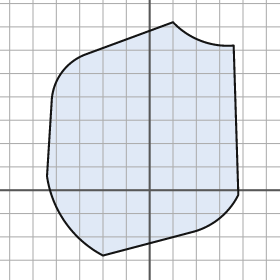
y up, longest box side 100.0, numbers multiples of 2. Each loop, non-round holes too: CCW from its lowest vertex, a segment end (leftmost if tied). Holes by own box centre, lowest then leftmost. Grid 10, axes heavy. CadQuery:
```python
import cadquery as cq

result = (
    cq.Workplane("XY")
    .moveTo(-20.0, -28.0)
    .lineTo(18.0, -18.0)
    .threePointArc((30.0, -12.0), (38.0, -2.0))
    .lineTo(36.0, 62.0)
    .threePointArc((22.0, 64.0), (10.0, 72.0))
    .lineTo(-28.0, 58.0)
    .threePointArc((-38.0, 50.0), (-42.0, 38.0))
    .lineTo(-44.0, 6.0)
    .threePointArc((-36.0, -14.0), (-20.0, -28.0))
    .close()
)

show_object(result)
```